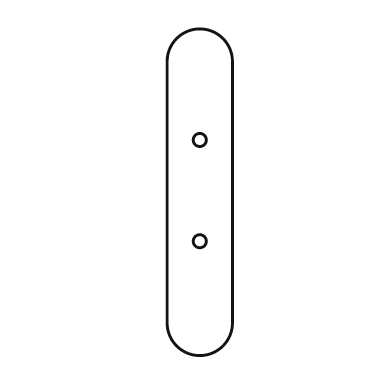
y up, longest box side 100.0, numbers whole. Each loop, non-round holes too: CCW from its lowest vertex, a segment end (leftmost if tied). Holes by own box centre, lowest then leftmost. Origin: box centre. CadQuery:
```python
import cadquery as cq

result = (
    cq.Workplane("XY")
    .moveTo(-10.0, -40.0)
    .threePointArc((0.0, -50.0), (10.0, -40.0))
    .lineTo(10.0, 40.0)
    .threePointArc((0.0, 50.0), (-10.0, 40.0))
    .close()
    .moveTo(0.0, -15.0)
    .circle(2.0)
    .moveTo(0.0, 16.0)
    .circle(2.0)
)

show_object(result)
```